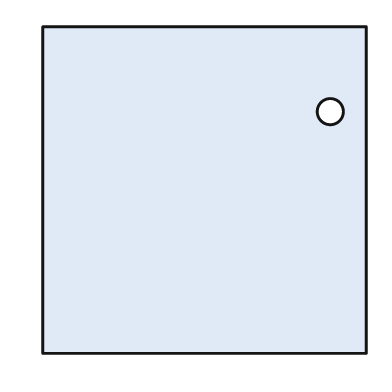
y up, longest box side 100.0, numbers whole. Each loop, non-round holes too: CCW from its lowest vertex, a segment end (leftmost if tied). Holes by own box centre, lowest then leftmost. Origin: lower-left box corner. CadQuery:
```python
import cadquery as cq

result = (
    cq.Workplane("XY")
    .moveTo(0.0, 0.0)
    .lineTo(99.0, 0.0)
    .lineTo(99.0, 100.0)
    .lineTo(0.0, 100.0)
    .close()
    .moveTo(88.0, 74.0)
    .circle(4.0)
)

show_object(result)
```